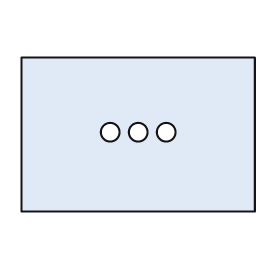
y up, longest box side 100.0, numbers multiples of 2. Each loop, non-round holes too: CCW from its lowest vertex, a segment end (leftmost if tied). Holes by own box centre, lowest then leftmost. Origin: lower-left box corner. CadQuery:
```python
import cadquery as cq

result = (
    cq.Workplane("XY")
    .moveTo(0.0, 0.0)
    .lineTo(100.0, 0.0)
    .lineTo(100.0, 66.0)
    .lineTo(0.0, 66.0)
    .close()
    .moveTo(38.0, 34.0)
    .circle(4.0)
    .moveTo(50.0, 34.0)
    .circle(4.0)
    .moveTo(62.0, 34.0)
    .circle(4.0)
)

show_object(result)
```